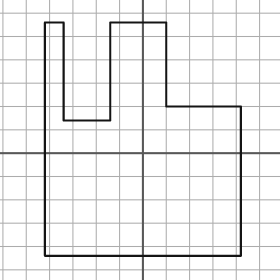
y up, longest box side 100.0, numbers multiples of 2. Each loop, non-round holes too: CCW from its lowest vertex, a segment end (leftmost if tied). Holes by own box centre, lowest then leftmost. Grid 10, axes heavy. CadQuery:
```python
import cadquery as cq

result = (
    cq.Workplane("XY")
    .moveTo(-42.0, -44.0)
    .lineTo(42.0, -44.0)
    .lineTo(42.0, 20.0)
    .lineTo(10.0, 20.0)
    .lineTo(10.0, 56.0)
    .lineTo(-14.0, 56.0)
    .lineTo(-14.0, 14.0)
    .lineTo(-34.0, 14.0)
    .lineTo(-34.0, 56.0)
    .lineTo(-42.0, 56.0)
    .close()
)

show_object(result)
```